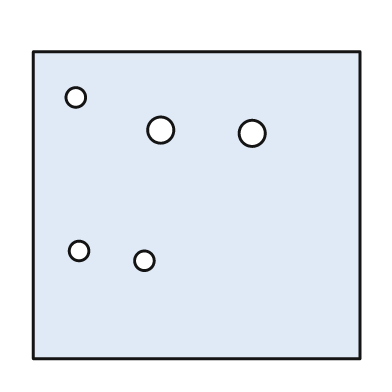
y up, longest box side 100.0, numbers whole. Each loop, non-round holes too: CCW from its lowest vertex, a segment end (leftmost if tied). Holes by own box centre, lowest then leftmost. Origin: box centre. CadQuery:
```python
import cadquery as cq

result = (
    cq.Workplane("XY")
    .moveTo(-50.0, -47.0)
    .lineTo(50.0, -47.0)
    .lineTo(50.0, 47.0)
    .lineTo(-50.0, 47.0)
    .close()
    .moveTo(-16.0, -17.0)
    .circle(3.0)
    .moveTo(-36.0, -14.0)
    .circle(3.0)
    .moveTo(17.0, 22.0)
    .circle(4.0)
    .moveTo(-11.0, 23.0)
    .circle(4.0)
    .moveTo(-37.0, 33.0)
    .circle(3.0)
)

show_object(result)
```